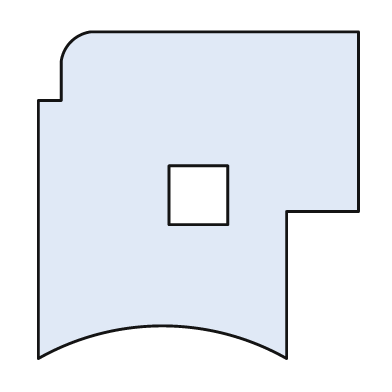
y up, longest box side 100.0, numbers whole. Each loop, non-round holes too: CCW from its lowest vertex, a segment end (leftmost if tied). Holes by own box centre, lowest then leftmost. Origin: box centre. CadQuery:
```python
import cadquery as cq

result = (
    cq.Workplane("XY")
    .moveTo(-49.0, -50.0)
    .threePointArc((-11.0, -40.0), (27.0, -50.0))
    .lineTo(27.0, -5.0)
    .lineTo(49.0, -5.0)
    .lineTo(49.0, 50.0)
    .lineTo(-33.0, 50.0)
    .threePointArc((-39.0, 47.0), (-42.0, 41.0))
    .lineTo(-42.0, 29.0)
    .lineTo(-49.0, 29.0)
    .close()
    .moveTo(-9.0, -9.0)
    .lineTo(9.0, -9.0)
    .lineTo(9.0, 9.0)
    .lineTo(-9.0, 9.0)
    .close()
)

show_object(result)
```